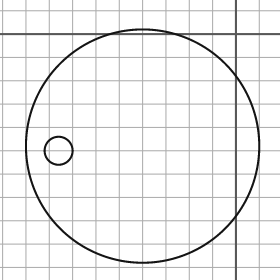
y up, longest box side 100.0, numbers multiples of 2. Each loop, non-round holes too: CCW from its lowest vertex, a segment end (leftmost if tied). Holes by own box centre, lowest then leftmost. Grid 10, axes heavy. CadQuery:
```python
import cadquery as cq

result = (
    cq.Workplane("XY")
    .moveTo(-40.0, -48.0)
    .circle(50.0)
    .moveTo(-76.0, -50.0)
    .circle(6.0)
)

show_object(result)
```